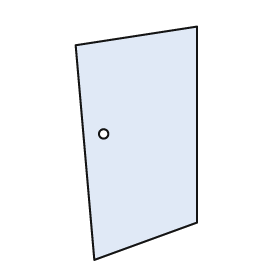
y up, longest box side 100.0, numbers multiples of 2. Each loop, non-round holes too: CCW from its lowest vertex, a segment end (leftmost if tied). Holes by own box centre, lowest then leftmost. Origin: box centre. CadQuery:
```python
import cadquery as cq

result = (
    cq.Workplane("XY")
    .moveTo(-18.0, -50.0)
    .lineTo(26.0, -34.0)
    .lineTo(26.0, 50.0)
    .lineTo(-26.0, 42.0)
    .close()
    .moveTo(-14.0, 4.0)
    .circle(2.0)
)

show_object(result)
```